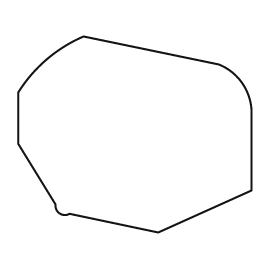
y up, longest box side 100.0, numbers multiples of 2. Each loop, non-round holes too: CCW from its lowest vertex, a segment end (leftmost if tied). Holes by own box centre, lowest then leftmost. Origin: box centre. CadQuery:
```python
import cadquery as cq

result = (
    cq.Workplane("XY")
    .moveTo(10.0, -42.0)
    .lineTo(50.0, -24.0)
    .lineTo(50.0, 10.0)
    .threePointArc((46.0, 22.0), (36.0, 30.0))
    .lineTo(-22.0, 42.0)
    .threePointArc((-38.0, 32.0), (-50.0, 18.0))
    .lineTo(-50.0, -4.0)
    .lineTo(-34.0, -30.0)
    .threePointArc((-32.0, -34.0), (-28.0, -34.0))
    .close()
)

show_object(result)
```